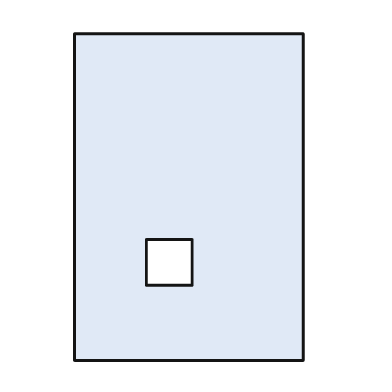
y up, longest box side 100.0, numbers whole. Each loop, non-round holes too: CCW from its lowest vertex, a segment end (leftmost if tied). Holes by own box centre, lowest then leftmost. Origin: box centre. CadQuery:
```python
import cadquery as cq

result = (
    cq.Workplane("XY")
    .moveTo(-35.0, -50.0)
    .lineTo(35.0, -50.0)
    .lineTo(35.0, 50.0)
    .lineTo(-35.0, 50.0)
    .close()
    .moveTo(-13.0, -27.0)
    .lineTo(1.0, -27.0)
    .lineTo(1.0, -13.0)
    .lineTo(-13.0, -13.0)
    .close()
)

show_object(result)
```